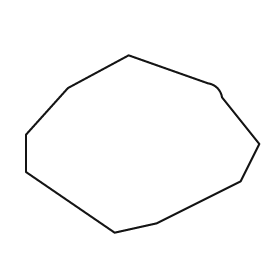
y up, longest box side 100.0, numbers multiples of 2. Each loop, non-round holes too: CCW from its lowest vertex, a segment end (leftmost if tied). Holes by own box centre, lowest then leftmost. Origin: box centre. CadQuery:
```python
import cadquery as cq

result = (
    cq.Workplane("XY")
    .moveTo(-12.0, -38.0)
    .lineTo(6.0, -34.0)
    .lineTo(42.0, -16.0)
    .lineTo(50.0, 0.0)
    .lineTo(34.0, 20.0)
    .threePointArc((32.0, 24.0), (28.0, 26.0))
    .lineTo(-6.0, 38.0)
    .lineTo(-32.0, 24.0)
    .lineTo(-50.0, 4.0)
    .lineTo(-50.0, -12.0)
    .close()
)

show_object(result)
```